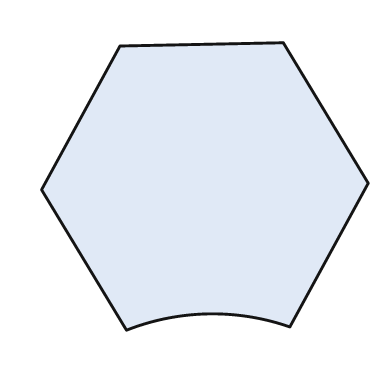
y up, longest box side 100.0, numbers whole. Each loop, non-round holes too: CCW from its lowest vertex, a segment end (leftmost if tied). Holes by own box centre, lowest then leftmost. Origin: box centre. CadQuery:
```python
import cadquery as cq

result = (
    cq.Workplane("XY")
    .moveTo(-24.0, -44.0)
    .threePointArc((1.0, -39.0), (26.0, -43.0))
    .lineTo(50.0, 1.0)
    .lineTo(24.0, 44.0)
    .lineTo(-26.0, 43.0)
    .lineTo(-50.0, -1.0)
    .close()
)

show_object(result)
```